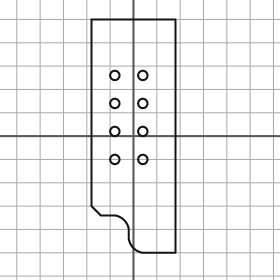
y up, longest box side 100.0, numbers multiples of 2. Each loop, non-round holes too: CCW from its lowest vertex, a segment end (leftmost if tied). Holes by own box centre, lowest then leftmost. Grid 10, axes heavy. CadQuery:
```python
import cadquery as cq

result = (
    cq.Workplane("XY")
    .moveTo(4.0, -50.0)
    .lineTo(18.0, -50.0)
    .lineTo(18.0, 50.0)
    .lineTo(-18.0, 50.0)
    .lineTo(-18.0, -30.0)
    .lineTo(-14.0, -34.0)
    .lineTo(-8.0, -34.0)
    .threePointArc((-4.0, -36.0), (-2.0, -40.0))
    .lineTo(-2.0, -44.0)
    .threePointArc((0.0, -48.0), (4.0, -50.0))
    .close()
    .moveTo(-8.0, -10.0)
    .circle(2.0)
    .moveTo(4.0, -10.0)
    .circle(2.0)
    .moveTo(-8.0, 2.0)
    .circle(2.0)
    .moveTo(4.0, 2.0)
    .circle(2.0)
    .moveTo(-8.0, 14.0)
    .circle(2.0)
    .moveTo(4.0, 14.0)
    .circle(2.0)
    .moveTo(-8.0, 26.0)
    .circle(2.0)
    .moveTo(4.0, 26.0)
    .circle(2.0)
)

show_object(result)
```